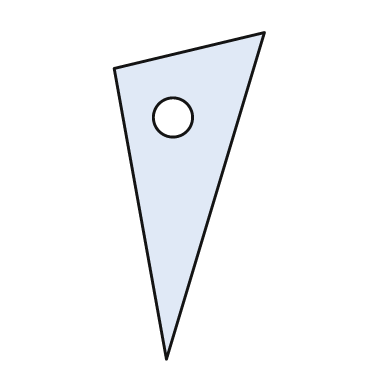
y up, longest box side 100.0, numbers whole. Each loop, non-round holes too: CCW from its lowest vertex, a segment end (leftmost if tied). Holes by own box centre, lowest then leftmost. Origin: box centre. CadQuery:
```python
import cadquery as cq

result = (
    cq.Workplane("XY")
    .moveTo(-7.0, -50.0)
    .lineTo(23.0, 50.0)
    .lineTo(-23.0, 39.0)
    .close()
    .moveTo(-5.0, 24.0)
    .circle(6.0)
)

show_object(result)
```